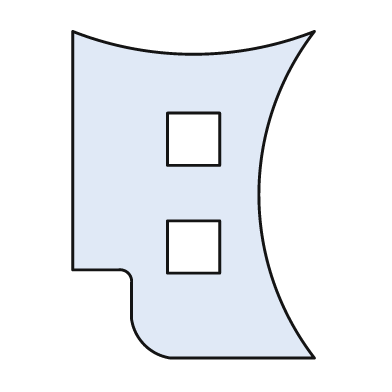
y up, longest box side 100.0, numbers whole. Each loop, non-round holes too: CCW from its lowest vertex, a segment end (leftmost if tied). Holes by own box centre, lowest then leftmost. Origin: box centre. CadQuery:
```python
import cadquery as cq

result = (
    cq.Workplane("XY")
    .moveTo(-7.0, -50.0)
    .lineTo(37.0, -50.0)
    .threePointArc((20.0, 0.0), (37.0, 50.0))
    .threePointArc((0.0, 43.0), (-37.0, 50.0))
    .lineTo(-37.0, -23.0)
    .lineTo(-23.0, -23.0)
    .threePointArc((-20.0, -24.0), (-19.0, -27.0))
    .lineTo(-19.0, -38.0)
    .threePointArc((-15.0, -46.0), (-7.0, -50.0))
    .close()
    .moveTo(-8.0, -24.0)
    .lineTo(8.0, -24.0)
    .lineTo(8.0, -8.0)
    .lineTo(-8.0, -8.0)
    .close()
    .moveTo(-8.0, 9.0)
    .lineTo(8.0, 9.0)
    .lineTo(8.0, 25.0)
    .lineTo(-8.0, 25.0)
    .close()
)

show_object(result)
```